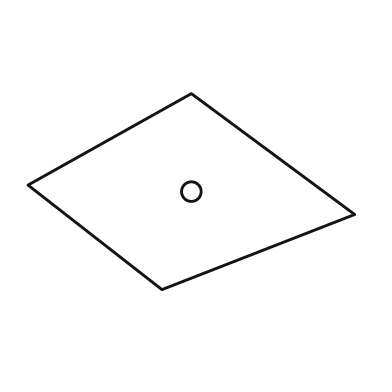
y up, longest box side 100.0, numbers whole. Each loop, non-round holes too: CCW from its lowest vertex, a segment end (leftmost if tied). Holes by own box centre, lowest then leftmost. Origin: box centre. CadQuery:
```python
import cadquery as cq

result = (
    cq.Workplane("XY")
    .moveTo(-9.0, -30.0)
    .lineTo(50.0, -7.0)
    .lineTo(0.0, 30.0)
    .lineTo(-50.0, 2.0)
    .close()
    .moveTo(0.0, 0.0)
    .circle(3.0)
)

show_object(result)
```